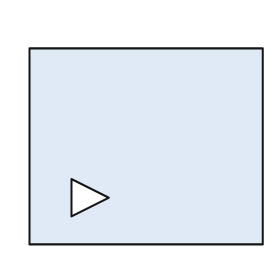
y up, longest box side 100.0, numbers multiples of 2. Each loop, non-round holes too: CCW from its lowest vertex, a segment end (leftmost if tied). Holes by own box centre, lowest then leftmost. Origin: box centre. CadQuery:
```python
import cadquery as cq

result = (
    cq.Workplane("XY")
    .moveTo(-50.0, -42.0)
    .lineTo(50.0, -42.0)
    .lineTo(50.0, 42.0)
    .lineTo(-50.0, 42.0)
    .close()
    .moveTo(-32.0, -30.0)
    .lineTo(-16.0, -22.0)
    .lineTo(-32.0, -14.0)
    .close()
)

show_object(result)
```